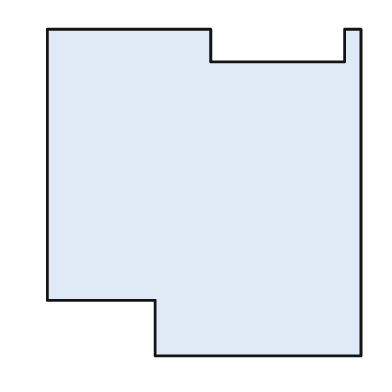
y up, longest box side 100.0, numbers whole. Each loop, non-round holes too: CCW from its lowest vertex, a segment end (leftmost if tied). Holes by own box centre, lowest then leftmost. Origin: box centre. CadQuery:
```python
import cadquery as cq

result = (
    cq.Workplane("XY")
    .moveTo(-15.0, -50.0)
    .lineTo(48.0, -50.0)
    .lineTo(48.0, 50.0)
    .lineTo(43.0, 50.0)
    .lineTo(43.0, 40.0)
    .lineTo(2.0, 40.0)
    .lineTo(2.0, 50.0)
    .lineTo(-48.0, 50.0)
    .lineTo(-48.0, -33.0)
    .lineTo(-15.0, -33.0)
    .close()
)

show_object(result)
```